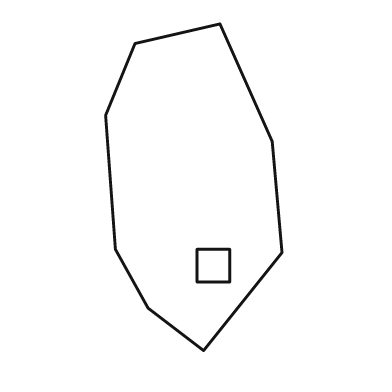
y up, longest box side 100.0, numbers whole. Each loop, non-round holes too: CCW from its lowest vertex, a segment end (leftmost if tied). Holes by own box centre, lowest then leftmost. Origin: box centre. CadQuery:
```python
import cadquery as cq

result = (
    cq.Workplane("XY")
    .moveTo(3.0, -50.0)
    .lineTo(27.0, -20.0)
    .lineTo(24.0, 14.0)
    .lineTo(8.0, 50.0)
    .lineTo(-18.0, 44.0)
    .lineTo(-27.0, 22.0)
    .lineTo(-24.0, -19.0)
    .lineTo(-14.0, -37.0)
    .close()
    .moveTo(1.0, -29.0)
    .lineTo(11.0, -29.0)
    .lineTo(11.0, -19.0)
    .lineTo(1.0, -19.0)
    .close()
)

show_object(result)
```